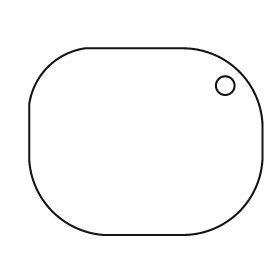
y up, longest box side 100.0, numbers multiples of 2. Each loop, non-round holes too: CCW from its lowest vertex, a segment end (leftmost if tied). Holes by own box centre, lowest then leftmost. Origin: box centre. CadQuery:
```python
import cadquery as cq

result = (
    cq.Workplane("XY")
    .moveTo(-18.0, -40.0)
    .lineTo(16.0, -40.0)
    .threePointArc((40.0, -30.0), (50.0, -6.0))
    .lineTo(50.0, 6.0)
    .threePointArc((40.0, 30.0), (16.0, 40.0))
    .lineTo(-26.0, 40.0)
    .threePointArc((-42.0, 32.0), (-50.0, 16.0))
    .lineTo(-50.0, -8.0)
    .threePointArc((-40.0, -30.0), (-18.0, -40.0))
    .close()
    .moveTo(34.0, 24.0)
    .circle(4.0)
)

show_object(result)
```